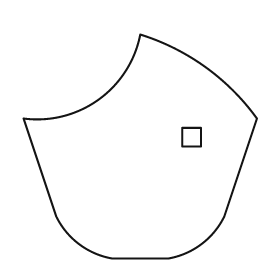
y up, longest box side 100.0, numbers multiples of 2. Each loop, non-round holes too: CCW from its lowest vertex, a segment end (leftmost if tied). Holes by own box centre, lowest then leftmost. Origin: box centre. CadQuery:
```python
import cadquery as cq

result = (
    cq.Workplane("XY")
    .moveTo(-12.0, -48.0)
    .lineTo(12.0, -48.0)
    .threePointArc((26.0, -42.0), (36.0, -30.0))
    .lineTo(50.0, 12.0)
    .threePointArc((28.0, 34.0), (0.0, 48.0))
    .threePointArc((-18.0, 20.0), (-50.0, 12.0))
    .lineTo(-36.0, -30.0)
    .threePointArc((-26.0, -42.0), (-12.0, -48.0))
    .close()
    .moveTo(18.0, 0.0)
    .lineTo(26.0, 0.0)
    .lineTo(26.0, 8.0)
    .lineTo(18.0, 8.0)
    .close()
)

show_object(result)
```